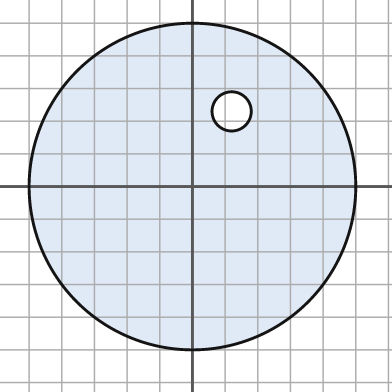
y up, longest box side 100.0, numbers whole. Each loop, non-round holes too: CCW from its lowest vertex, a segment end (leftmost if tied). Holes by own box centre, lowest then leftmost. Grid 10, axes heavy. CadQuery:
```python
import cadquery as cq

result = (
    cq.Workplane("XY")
    .moveTo(0.0, 0.0)
    .circle(50.0)
    .moveTo(12.0, 23.0)
    .circle(6.0)
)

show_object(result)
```